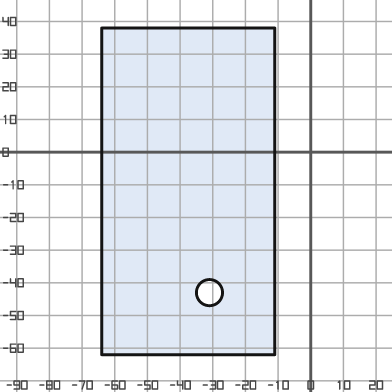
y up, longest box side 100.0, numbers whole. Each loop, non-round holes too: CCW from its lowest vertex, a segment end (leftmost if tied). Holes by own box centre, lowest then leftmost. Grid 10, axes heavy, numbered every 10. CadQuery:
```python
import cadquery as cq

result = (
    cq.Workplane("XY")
    .moveTo(-64.0, -62.0)
    .lineTo(-11.0, -62.0)
    .lineTo(-11.0, 38.0)
    .lineTo(-64.0, 38.0)
    .close()
    .moveTo(-31.0, -43.0)
    .circle(4.0)
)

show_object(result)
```